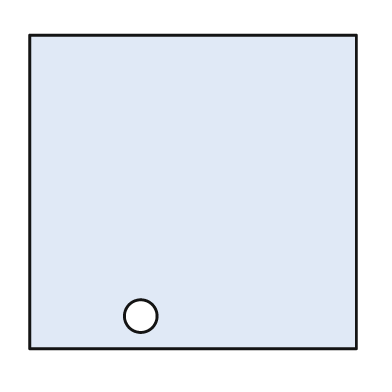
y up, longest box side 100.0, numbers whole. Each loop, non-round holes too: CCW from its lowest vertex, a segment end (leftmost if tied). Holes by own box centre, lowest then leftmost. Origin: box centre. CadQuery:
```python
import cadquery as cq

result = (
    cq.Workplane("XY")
    .moveTo(-50.0, -48.0)
    .lineTo(50.0, -48.0)
    .lineTo(50.0, 48.0)
    .lineTo(-50.0, 48.0)
    .close()
    .moveTo(-16.0, -38.0)
    .circle(5.0)
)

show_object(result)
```